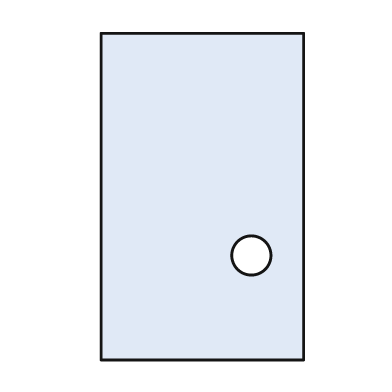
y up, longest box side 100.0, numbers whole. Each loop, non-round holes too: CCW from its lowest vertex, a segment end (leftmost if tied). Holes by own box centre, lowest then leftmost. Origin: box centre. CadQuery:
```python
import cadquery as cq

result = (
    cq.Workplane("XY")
    .moveTo(-31.0, -50.0)
    .lineTo(31.0, -50.0)
    .lineTo(31.0, 50.0)
    .lineTo(-31.0, 50.0)
    .close()
    .moveTo(15.0, -18.0)
    .circle(6.0)
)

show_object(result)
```